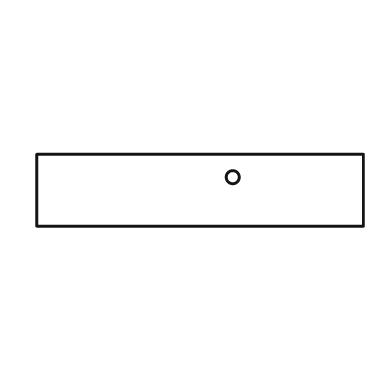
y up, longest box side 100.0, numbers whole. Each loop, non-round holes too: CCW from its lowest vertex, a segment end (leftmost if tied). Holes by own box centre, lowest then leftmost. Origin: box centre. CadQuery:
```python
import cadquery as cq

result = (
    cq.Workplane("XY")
    .moveTo(-50.0, -11.0)
    .lineTo(50.0, -11.0)
    .lineTo(50.0, 11.0)
    .lineTo(-50.0, 11.0)
    .close()
    .moveTo(10.0, 4.0)
    .circle(2.0)
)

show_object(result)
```